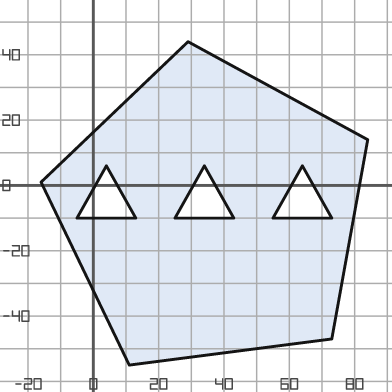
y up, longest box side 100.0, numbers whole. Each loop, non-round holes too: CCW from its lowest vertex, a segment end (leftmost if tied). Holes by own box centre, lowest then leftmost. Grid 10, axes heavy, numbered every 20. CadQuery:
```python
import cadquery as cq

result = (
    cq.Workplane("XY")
    .moveTo(11.0, -55.0)
    .lineTo(73.0, -47.0)
    .lineTo(84.0, 14.0)
    .lineTo(29.0, 44.0)
    .lineTo(-16.0, 1.0)
    .close()
    .moveTo(-5.0, -10.0)
    .lineTo(13.0, -10.0)
    .lineTo(4.0, 6.0)
    .close()
    .moveTo(25.0, -10.0)
    .lineTo(43.0, -10.0)
    .lineTo(34.0, 6.0)
    .close()
    .moveTo(55.0, -10.0)
    .lineTo(73.0, -10.0)
    .lineTo(64.0, 6.0)
    .close()
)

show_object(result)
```